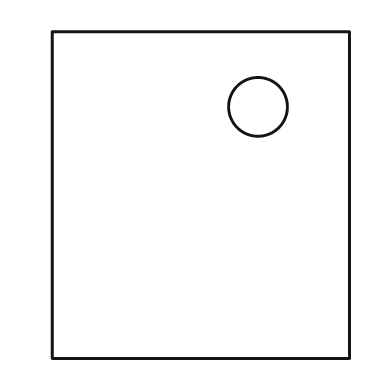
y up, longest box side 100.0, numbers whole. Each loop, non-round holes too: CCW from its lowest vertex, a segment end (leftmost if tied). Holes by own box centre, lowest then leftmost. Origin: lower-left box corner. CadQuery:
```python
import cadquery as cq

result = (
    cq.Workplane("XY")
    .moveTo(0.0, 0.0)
    .lineTo(91.0, 0.0)
    .lineTo(91.0, 100.0)
    .lineTo(0.0, 100.0)
    .close()
    .moveTo(63.0, 77.0)
    .circle(9.0)
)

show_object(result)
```